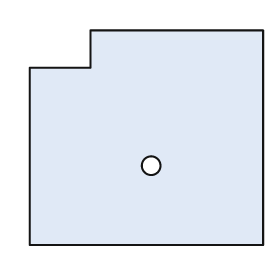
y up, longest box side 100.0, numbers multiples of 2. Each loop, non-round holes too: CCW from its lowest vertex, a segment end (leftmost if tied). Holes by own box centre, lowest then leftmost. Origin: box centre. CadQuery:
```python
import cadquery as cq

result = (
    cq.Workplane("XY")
    .moveTo(-50.0, -46.0)
    .lineTo(50.0, -46.0)
    .lineTo(50.0, 46.0)
    .lineTo(-24.0, 46.0)
    .lineTo(-24.0, 30.0)
    .lineTo(-50.0, 30.0)
    .close()
    .moveTo(2.0, -12.0)
    .circle(4.0)
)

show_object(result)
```